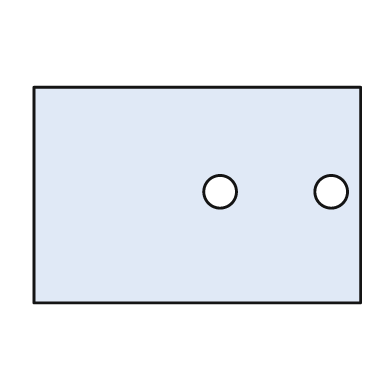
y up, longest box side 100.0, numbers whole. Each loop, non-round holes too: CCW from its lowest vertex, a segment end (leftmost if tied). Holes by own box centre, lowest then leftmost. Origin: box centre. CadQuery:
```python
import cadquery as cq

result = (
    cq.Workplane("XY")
    .moveTo(-50.0, -33.0)
    .lineTo(50.0, -33.0)
    .lineTo(50.0, 33.0)
    .lineTo(-50.0, 33.0)
    .close()
    .moveTo(7.0, 1.0)
    .circle(5.0)
    .moveTo(41.0, 1.0)
    .circle(5.0)
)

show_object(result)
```